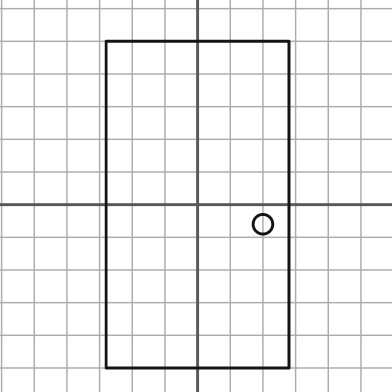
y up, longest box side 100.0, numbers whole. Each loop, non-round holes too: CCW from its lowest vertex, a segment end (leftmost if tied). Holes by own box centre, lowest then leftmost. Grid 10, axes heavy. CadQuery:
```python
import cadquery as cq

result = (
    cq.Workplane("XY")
    .moveTo(-28.0, -50.0)
    .lineTo(28.0, -50.0)
    .lineTo(28.0, 50.0)
    .lineTo(-28.0, 50.0)
    .close()
    .moveTo(20.0, -6.0)
    .circle(3.0)
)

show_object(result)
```